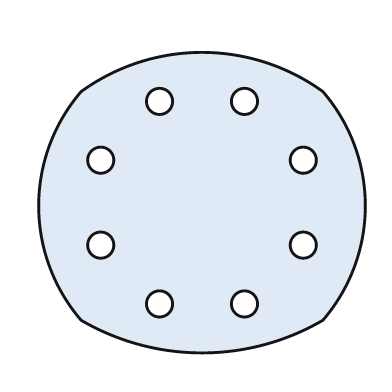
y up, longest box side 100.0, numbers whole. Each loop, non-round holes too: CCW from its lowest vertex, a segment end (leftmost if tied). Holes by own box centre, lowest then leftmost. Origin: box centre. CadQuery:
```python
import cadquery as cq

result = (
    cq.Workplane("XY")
    .moveTo(-37.0, -36.0)
    .threePointArc((0.0, -46.0), (37.0, -36.0))
    .threePointArc((50.0, -1.0), (37.0, 34.0))
    .threePointArc((0.0, 46.0), (-37.0, 34.0))
    .threePointArc((-50.0, -1.0), (-37.0, -36.0))
    .close()
    .moveTo(-13.0, -31.0)
    .circle(4.0)
    .moveTo(13.0, -31.0)
    .circle(4.0)
    .moveTo(-31.0, -13.0)
    .circle(4.0)
    .moveTo(31.0, -13.0)
    .circle(4.0)
    .moveTo(-31.0, 13.0)
    .circle(4.0)
    .moveTo(31.0, 13.0)
    .circle(4.0)
    .moveTo(-13.0, 31.0)
    .circle(4.0)
    .moveTo(13.0, 31.0)
    .circle(4.0)
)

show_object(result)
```